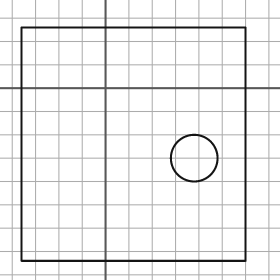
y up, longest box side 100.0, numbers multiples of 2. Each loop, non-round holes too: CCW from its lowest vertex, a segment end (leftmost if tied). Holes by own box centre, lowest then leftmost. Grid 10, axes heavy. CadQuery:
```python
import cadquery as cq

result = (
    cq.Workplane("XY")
    .moveTo(-36.0, -74.0)
    .lineTo(60.0, -74.0)
    .lineTo(60.0, 26.0)
    .lineTo(-36.0, 26.0)
    .close()
    .moveTo(38.0, -30.0)
    .circle(10.0)
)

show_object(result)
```